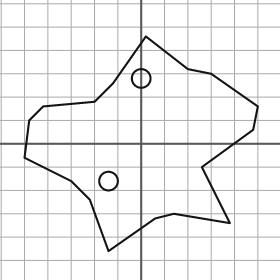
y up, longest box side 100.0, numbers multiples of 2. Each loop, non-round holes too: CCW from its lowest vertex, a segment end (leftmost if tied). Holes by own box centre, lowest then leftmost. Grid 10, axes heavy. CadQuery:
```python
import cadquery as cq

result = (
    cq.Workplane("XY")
    .moveTo(-14.0, -46.0)
    .lineTo(6.0, -32.0)
    .lineTo(14.0, -30.0)
    .lineTo(38.0, -34.0)
    .lineTo(26.0, -10.0)
    .lineTo(48.0, 6.0)
    .lineTo(50.0, 16.0)
    .lineTo(30.0, 30.0)
    .lineTo(20.0, 32.0)
    .lineTo(2.0, 46.0)
    .lineTo(-12.0, 26.0)
    .lineTo(-20.0, 18.0)
    .lineTo(-42.0, 16.0)
    .lineTo(-48.0, 10.0)
    .lineTo(-50.0, -6.0)
    .lineTo(-30.0, -16.0)
    .lineTo(-22.0, -24.0)
    .close()
    .moveTo(-14.0, -16.0)
    .circle(4.0)
    .moveTo(0.0, 28.0)
    .circle(4.0)
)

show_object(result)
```